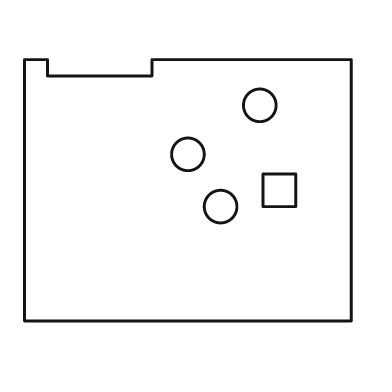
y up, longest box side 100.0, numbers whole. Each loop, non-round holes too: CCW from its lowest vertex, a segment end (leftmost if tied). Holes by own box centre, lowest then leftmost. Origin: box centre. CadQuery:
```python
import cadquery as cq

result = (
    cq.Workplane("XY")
    .moveTo(-50.0, -40.0)
    .lineTo(50.0, -40.0)
    .lineTo(50.0, 40.0)
    .lineTo(-11.0, 40.0)
    .lineTo(-11.0, 35.0)
    .lineTo(-43.0, 35.0)
    .lineTo(-43.0, 40.0)
    .lineTo(-50.0, 40.0)
    .close()
    .moveTo(10.0, -5.0)
    .circle(5.0)
    .moveTo(23.0, -5.0)
    .lineTo(33.0, -5.0)
    .lineTo(33.0, 5.0)
    .lineTo(23.0, 5.0)
    .close()
    .moveTo(0.0, 11.0)
    .circle(5.0)
    .moveTo(22.0, 26.0)
    .circle(5.0)
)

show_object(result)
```